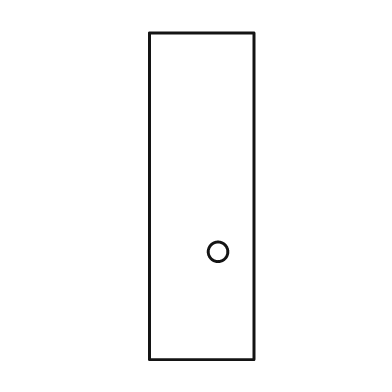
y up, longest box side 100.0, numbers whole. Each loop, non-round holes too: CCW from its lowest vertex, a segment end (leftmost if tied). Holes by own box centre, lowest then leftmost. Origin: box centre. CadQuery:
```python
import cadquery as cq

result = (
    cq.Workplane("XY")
    .moveTo(-16.0, -50.0)
    .lineTo(16.0, -50.0)
    .lineTo(16.0, 50.0)
    .lineTo(-16.0, 50.0)
    .close()
    .moveTo(5.0, -17.0)
    .circle(3.0)
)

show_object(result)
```